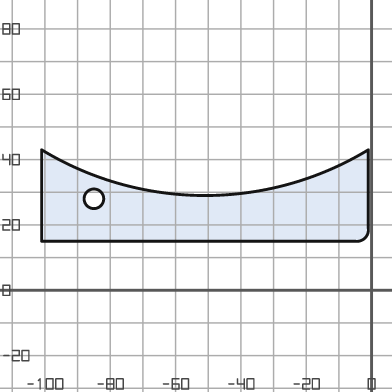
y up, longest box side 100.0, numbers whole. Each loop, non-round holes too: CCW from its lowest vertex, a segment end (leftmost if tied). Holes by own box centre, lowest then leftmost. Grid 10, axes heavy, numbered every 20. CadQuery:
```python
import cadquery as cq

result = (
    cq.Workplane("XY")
    .moveTo(-101.0, 15.0)
    .lineTo(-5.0, 15.0)
    .threePointArc((-2.0, 16.0), (-1.0, 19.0))
    .lineTo(-1.0, 43.0)
    .threePointArc((-51.0, 29.0), (-101.0, 43.0))
    .close()
    .moveTo(-85.0, 28.0)
    .circle(3.0)
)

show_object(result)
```